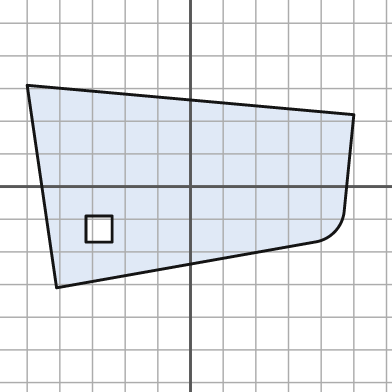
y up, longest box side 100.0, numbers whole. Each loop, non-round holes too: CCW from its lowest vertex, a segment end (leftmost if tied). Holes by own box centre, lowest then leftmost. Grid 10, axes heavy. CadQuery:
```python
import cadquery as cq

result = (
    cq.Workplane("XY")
    .moveTo(-41.0, -31.0)
    .lineTo(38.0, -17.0)
    .threePointArc((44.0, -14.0), (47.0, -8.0))
    .lineTo(50.0, 22.0)
    .lineTo(-50.0, 31.0)
    .close()
    .moveTo(-32.0, -17.0)
    .lineTo(-24.0, -17.0)
    .lineTo(-24.0, -9.0)
    .lineTo(-32.0, -9.0)
    .close()
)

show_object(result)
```